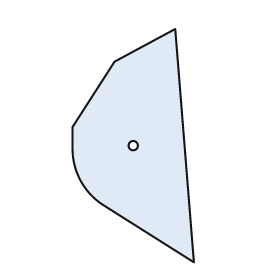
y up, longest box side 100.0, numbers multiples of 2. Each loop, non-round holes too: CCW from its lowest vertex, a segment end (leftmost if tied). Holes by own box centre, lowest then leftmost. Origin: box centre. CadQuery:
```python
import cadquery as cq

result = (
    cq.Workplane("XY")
    .moveTo(26.0, -50.0)
    .lineTo(18.0, 50.0)
    .lineTo(-8.0, 36.0)
    .lineTo(-26.0, 8.0)
    .lineTo(-26.0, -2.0)
    .threePointArc((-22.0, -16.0), (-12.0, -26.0))
    .close()
    .moveTo(0.0, 0.0)
    .circle(2.0)
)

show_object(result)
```